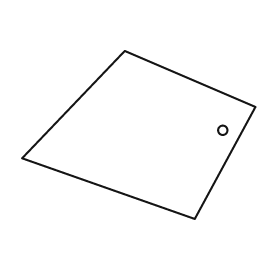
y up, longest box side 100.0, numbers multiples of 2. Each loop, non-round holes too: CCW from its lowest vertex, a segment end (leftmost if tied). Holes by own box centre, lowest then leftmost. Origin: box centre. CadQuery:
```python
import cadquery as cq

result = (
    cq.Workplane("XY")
    .moveTo(24.0, -36.0)
    .lineTo(50.0, 12.0)
    .lineTo(-6.0, 36.0)
    .lineTo(-50.0, -10.0)
    .close()
    .moveTo(36.0, 2.0)
    .circle(2.0)
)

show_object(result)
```